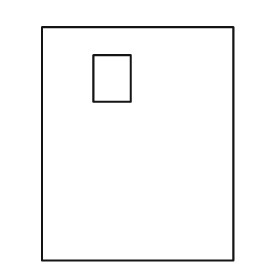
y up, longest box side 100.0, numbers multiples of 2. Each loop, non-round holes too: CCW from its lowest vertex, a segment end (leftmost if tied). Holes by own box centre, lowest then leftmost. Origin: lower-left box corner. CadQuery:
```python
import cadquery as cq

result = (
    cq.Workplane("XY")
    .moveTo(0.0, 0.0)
    .lineTo(82.0, 0.0)
    .lineTo(82.0, 100.0)
    .lineTo(0.0, 100.0)
    .close()
    .moveTo(22.0, 68.0)
    .lineTo(38.0, 68.0)
    .lineTo(38.0, 88.0)
    .lineTo(22.0, 88.0)
    .close()
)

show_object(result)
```